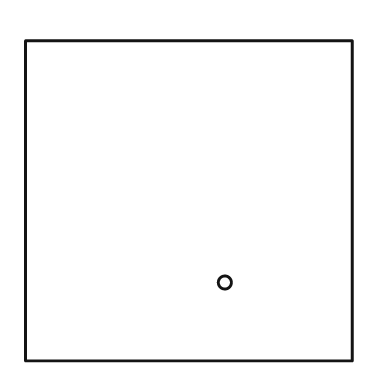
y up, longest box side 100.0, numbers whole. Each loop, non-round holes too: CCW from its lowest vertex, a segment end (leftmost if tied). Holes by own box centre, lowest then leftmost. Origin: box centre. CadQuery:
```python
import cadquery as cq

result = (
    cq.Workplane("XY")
    .moveTo(-50.0, -49.0)
    .lineTo(50.0, -49.0)
    .lineTo(50.0, 49.0)
    .lineTo(-50.0, 49.0)
    .close()
    .moveTo(11.0, -25.0)
    .circle(2.0)
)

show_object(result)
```